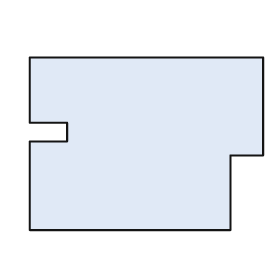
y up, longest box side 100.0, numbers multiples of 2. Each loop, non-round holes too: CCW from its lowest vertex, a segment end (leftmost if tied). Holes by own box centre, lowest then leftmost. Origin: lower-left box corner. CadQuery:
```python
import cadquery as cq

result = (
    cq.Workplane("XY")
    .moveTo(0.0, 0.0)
    .lineTo(86.0, 0.0)
    .lineTo(86.0, 32.0)
    .lineTo(100.0, 32.0)
    .lineTo(100.0, 74.0)
    .lineTo(0.0, 74.0)
    .lineTo(0.0, 46.0)
    .lineTo(16.0, 46.0)
    .lineTo(16.0, 38.0)
    .lineTo(0.0, 38.0)
    .close()
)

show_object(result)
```